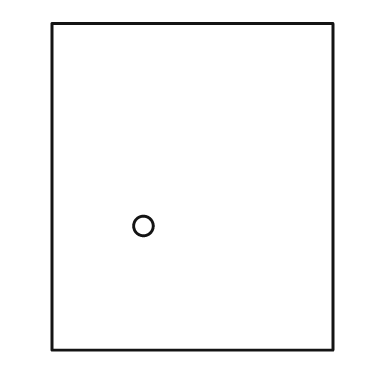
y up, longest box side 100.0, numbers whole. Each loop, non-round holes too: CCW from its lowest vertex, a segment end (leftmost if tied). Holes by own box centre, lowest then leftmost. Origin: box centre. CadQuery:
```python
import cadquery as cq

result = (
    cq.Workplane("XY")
    .moveTo(-43.0, -50.0)
    .lineTo(43.0, -50.0)
    .lineTo(43.0, 50.0)
    .lineTo(-43.0, 50.0)
    .close()
    .moveTo(-15.0, -12.0)
    .circle(3.0)
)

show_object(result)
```